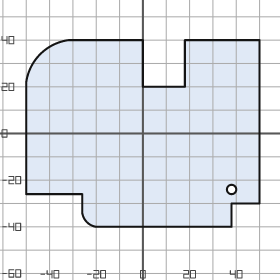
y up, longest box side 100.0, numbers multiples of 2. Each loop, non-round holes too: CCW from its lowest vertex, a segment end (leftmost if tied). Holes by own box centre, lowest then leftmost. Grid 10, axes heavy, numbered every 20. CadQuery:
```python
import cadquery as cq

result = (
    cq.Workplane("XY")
    .moveTo(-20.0, -40.0)
    .lineTo(38.0, -40.0)
    .lineTo(38.0, -30.0)
    .lineTo(50.0, -30.0)
    .lineTo(50.0, 40.0)
    .lineTo(18.0, 40.0)
    .lineTo(18.0, 20.0)
    .lineTo(0.0, 20.0)
    .lineTo(0.0, 40.0)
    .lineTo(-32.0, 40.0)
    .threePointArc((-44.0, 34.0), (-50.0, 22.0))
    .lineTo(-50.0, -26.0)
    .lineTo(-26.0, -26.0)
    .lineTo(-26.0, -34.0)
    .threePointArc((-24.0, -38.0), (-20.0, -40.0))
    .close()
    .moveTo(38.0, -24.0)
    .circle(2.0)
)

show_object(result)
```